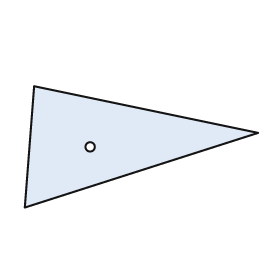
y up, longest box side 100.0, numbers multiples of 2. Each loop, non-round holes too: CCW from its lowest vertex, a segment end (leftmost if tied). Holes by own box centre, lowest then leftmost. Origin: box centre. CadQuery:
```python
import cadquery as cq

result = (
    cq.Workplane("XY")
    .moveTo(-50.0, -26.0)
    .lineTo(50.0, 6.0)
    .lineTo(-46.0, 26.0)
    .close()
    .moveTo(-22.0, 0.0)
    .circle(2.0)
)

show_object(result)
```